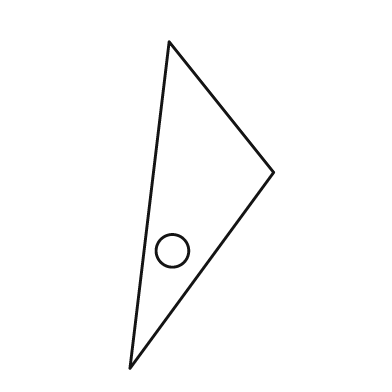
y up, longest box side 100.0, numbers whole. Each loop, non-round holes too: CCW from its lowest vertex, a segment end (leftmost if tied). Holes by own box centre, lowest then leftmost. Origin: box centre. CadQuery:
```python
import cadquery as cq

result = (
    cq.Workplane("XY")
    .moveTo(-22.0, -50.0)
    .lineTo(22.0, 10.0)
    .lineTo(-10.0, 50.0)
    .close()
    .moveTo(-9.0, -14.0)
    .circle(5.0)
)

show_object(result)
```